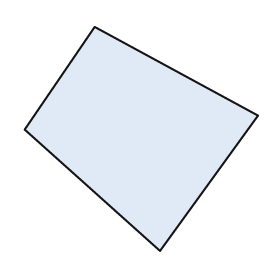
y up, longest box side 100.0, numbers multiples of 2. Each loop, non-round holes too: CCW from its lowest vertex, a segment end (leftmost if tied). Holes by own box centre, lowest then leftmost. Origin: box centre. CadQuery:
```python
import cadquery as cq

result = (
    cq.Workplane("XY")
    .moveTo(8.0, -48.0)
    .lineTo(50.0, 10.0)
    .lineTo(-20.0, 48.0)
    .lineTo(-50.0, 4.0)
    .close()
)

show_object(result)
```